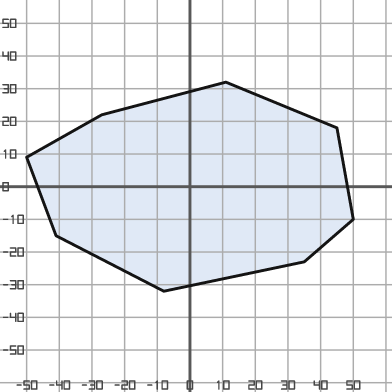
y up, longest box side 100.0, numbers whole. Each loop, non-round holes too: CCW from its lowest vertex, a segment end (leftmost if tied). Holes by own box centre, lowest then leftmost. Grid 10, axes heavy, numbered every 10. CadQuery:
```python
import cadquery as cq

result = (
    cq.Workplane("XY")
    .moveTo(-8.0, -32.0)
    .lineTo(35.0, -23.0)
    .lineTo(50.0, -10.0)
    .lineTo(45.0, 18.0)
    .lineTo(11.0, 32.0)
    .lineTo(-27.0, 22.0)
    .lineTo(-50.0, 9.0)
    .lineTo(-41.0, -15.0)
    .close()
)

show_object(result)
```